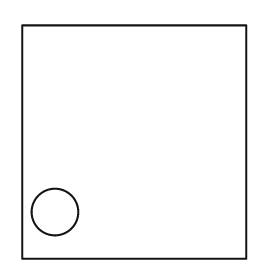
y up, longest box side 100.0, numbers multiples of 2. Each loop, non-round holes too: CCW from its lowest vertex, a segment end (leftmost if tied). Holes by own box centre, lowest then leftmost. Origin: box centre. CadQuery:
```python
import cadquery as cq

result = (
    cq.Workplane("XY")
    .moveTo(-48.0, -50.0)
    .lineTo(48.0, -50.0)
    .lineTo(48.0, 50.0)
    .lineTo(-48.0, 50.0)
    .close()
    .moveTo(-34.0, -30.0)
    .circle(10.0)
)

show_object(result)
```